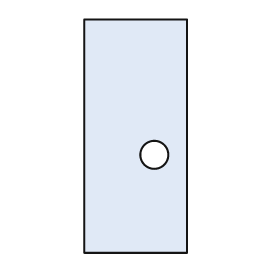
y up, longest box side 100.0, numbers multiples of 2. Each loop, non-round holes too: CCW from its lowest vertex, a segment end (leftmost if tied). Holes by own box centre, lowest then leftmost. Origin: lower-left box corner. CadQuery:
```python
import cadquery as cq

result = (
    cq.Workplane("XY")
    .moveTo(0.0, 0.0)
    .lineTo(44.0, 0.0)
    .lineTo(44.0, 100.0)
    .lineTo(0.0, 100.0)
    .close()
    .moveTo(30.0, 42.0)
    .circle(6.0)
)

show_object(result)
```